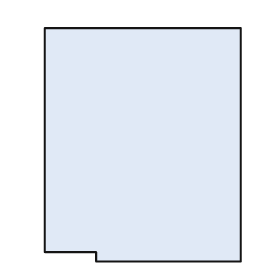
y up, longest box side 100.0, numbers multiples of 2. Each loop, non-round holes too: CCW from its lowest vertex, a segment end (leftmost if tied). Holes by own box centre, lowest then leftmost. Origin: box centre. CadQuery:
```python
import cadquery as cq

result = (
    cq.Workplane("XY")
    .moveTo(-20.0, -50.0)
    .lineTo(42.0, -50.0)
    .lineTo(42.0, 50.0)
    .lineTo(-42.0, 50.0)
    .lineTo(-42.0, -46.0)
    .lineTo(-20.0, -46.0)
    .close()
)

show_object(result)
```